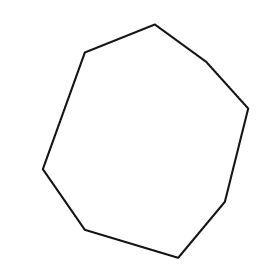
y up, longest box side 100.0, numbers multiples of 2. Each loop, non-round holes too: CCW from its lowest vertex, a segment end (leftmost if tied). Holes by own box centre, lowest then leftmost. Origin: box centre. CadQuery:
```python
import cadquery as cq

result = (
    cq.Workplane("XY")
    .moveTo(14.0, -50.0)
    .lineTo(34.0, -26.0)
    .lineTo(44.0, 14.0)
    .lineTo(26.0, 34.0)
    .lineTo(4.0, 50.0)
    .lineTo(-26.0, 38.0)
    .lineTo(-44.0, -12.0)
    .lineTo(-26.0, -38.0)
    .close()
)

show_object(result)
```